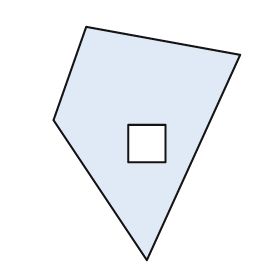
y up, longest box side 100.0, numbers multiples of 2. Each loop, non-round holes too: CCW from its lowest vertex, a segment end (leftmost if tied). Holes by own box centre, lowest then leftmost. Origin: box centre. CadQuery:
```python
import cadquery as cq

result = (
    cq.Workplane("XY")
    .moveTo(0.0, -50.0)
    .lineTo(40.0, 38.0)
    .lineTo(-26.0, 50.0)
    .lineTo(-40.0, 10.0)
    .close()
    .moveTo(-8.0, -8.0)
    .lineTo(8.0, -8.0)
    .lineTo(8.0, 8.0)
    .lineTo(-8.0, 8.0)
    .close()
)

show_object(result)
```